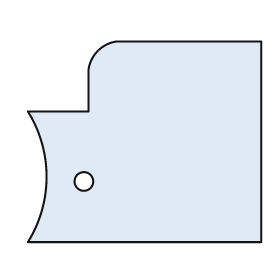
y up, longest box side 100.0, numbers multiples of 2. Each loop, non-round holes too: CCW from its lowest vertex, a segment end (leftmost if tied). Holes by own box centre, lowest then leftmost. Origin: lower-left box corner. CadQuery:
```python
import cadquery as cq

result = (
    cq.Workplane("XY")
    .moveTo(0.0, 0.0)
    .lineTo(100.0, 0.0)
    .lineTo(100.0, 86.0)
    .lineTo(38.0, 86.0)
    .threePointArc((30.0, 82.0), (26.0, 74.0))
    .lineTo(26.0, 56.0)
    .lineTo(0.0, 56.0)
    .threePointArc((8.0, 28.0), (0.0, 0.0))
    .close()
    .moveTo(24.0, 26.0)
    .circle(4.0)
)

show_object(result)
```